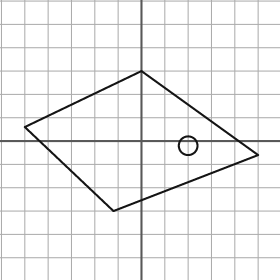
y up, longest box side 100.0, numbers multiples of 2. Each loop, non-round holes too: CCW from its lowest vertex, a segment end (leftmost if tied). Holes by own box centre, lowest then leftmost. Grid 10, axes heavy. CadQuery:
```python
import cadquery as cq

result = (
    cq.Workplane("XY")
    .moveTo(-12.0, -30.0)
    .lineTo(50.0, -6.0)
    .lineTo(0.0, 30.0)
    .lineTo(-50.0, 6.0)
    .close()
    .moveTo(20.0, -2.0)
    .circle(4.0)
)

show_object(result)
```